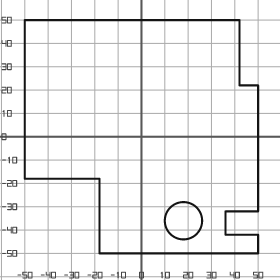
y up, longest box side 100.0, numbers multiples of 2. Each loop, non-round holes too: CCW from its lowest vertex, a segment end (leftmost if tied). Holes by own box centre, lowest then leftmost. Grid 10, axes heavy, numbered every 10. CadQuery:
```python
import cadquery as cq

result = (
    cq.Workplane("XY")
    .moveTo(-18.0, -50.0)
    .lineTo(50.0, -50.0)
    .lineTo(50.0, -42.0)
    .lineTo(36.0, -42.0)
    .lineTo(36.0, -32.0)
    .lineTo(50.0, -32.0)
    .lineTo(50.0, 22.0)
    .lineTo(42.0, 22.0)
    .lineTo(42.0, 50.0)
    .lineTo(-50.0, 50.0)
    .lineTo(-50.0, -18.0)
    .lineTo(-18.0, -18.0)
    .close()
    .moveTo(18.0, -36.0)
    .circle(8.0)
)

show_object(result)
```